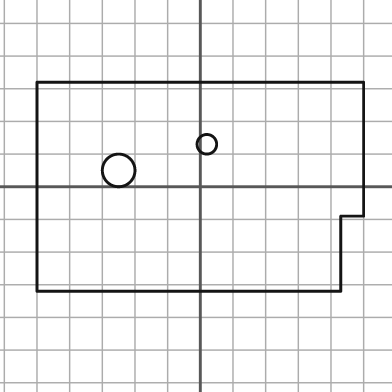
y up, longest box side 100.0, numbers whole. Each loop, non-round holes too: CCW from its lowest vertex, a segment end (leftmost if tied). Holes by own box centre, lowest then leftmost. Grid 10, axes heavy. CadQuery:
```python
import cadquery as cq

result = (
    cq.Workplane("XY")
    .moveTo(-50.0, -32.0)
    .lineTo(43.0, -32.0)
    .lineTo(43.0, -9.0)
    .lineTo(50.0, -9.0)
    .lineTo(50.0, 32.0)
    .lineTo(-50.0, 32.0)
    .close()
    .moveTo(-25.0, 5.0)
    .circle(5.0)
    .moveTo(2.0, 13.0)
    .circle(3.0)
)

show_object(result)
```